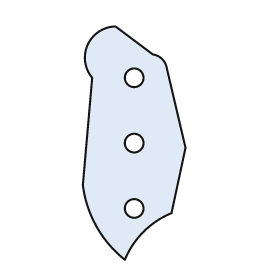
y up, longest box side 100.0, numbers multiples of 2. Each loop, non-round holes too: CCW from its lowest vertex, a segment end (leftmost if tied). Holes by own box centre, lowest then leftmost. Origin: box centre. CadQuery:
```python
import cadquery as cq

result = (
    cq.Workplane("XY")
    .moveTo(-4.0, -50.0)
    .threePointArc((4.0, -38.0), (16.0, -30.0))
    .lineTo(22.0, -2.0)
    .lineTo(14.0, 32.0)
    .threePointArc((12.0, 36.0), (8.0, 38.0))
    .lineTo(-8.0, 50.0)
    .threePointArc((-20.0, 42.0), (-18.0, 28.0))
    .lineTo(-22.0, -18.0)
    .threePointArc((-16.0, -36.0), (-4.0, -50.0))
    .close()
    .moveTo(0.0, -28.0)
    .circle(4.0)
    .moveTo(0.0, 0.0)
    .circle(4.0)
    .moveTo(0.0, 28.0)
    .circle(4.0)
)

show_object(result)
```